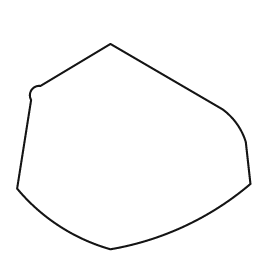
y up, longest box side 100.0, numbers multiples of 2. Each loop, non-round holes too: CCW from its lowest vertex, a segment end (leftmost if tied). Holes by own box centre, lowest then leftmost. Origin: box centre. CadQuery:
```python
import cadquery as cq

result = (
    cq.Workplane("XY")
    .moveTo(-10.0, -44.0)
    .threePointArc((22.0, -34.0), (50.0, -16.0))
    .lineTo(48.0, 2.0)
    .threePointArc((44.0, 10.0), (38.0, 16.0))
    .lineTo(-10.0, 44.0)
    .lineTo(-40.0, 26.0)
    .threePointArc((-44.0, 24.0), (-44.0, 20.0))
    .lineTo(-50.0, -18.0)
    .threePointArc((-32.0, -34.0), (-10.0, -44.0))
    .close()
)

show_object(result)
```